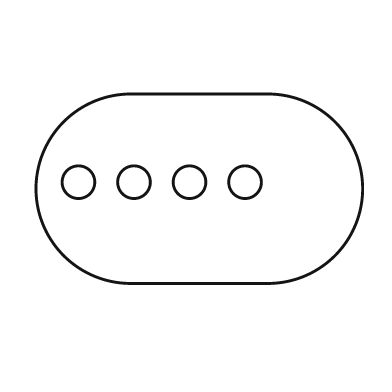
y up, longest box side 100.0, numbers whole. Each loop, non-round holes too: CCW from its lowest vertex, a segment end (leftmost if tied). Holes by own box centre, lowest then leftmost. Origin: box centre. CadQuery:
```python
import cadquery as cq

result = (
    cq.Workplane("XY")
    .moveTo(-21.0, -29.0)
    .lineTo(21.0, -29.0)
    .threePointArc((50.0, 0.0), (21.0, 29.0))
    .lineTo(-21.0, 29.0)
    .threePointArc((-50.0, 0.0), (-21.0, -29.0))
    .close()
    .moveTo(-37.0, 2.0)
    .circle(5.0)
    .moveTo(-20.0, 2.0)
    .circle(5.0)
    .moveTo(-3.0, 2.0)
    .circle(5.0)
    .moveTo(14.0, 2.0)
    .circle(5.0)
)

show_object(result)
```